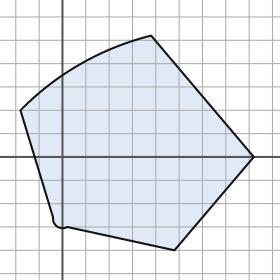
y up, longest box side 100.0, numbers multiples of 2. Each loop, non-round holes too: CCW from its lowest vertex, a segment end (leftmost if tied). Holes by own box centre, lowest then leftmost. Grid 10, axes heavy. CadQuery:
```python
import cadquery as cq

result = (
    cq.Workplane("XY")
    .moveTo(48.0, -40.0)
    .lineTo(82.0, 0.0)
    .lineTo(38.0, 52.0)
    .threePointArc((8.0, 40.0), (-18.0, 20.0))
    .lineTo(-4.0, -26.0)
    .threePointArc((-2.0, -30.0), (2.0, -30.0))
    .close()
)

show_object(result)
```